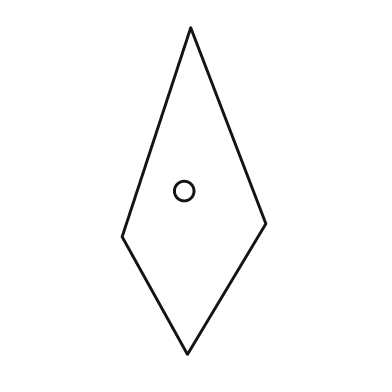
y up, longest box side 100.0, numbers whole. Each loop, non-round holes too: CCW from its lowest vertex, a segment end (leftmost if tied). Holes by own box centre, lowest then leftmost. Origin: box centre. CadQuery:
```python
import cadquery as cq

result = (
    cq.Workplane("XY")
    .moveTo(-2.0, -50.0)
    .lineTo(22.0, -10.0)
    .lineTo(-1.0, 50.0)
    .lineTo(-22.0, -14.0)
    .close()
    .moveTo(-3.0, 0.0)
    .circle(3.0)
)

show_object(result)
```